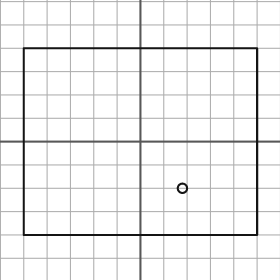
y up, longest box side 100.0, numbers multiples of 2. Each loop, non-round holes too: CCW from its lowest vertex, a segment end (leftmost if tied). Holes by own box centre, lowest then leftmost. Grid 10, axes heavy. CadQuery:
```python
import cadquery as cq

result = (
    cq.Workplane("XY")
    .moveTo(-50.0, -40.0)
    .lineTo(50.0, -40.0)
    .lineTo(50.0, 40.0)
    .lineTo(-50.0, 40.0)
    .close()
    .moveTo(18.0, -20.0)
    .circle(2.0)
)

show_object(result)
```